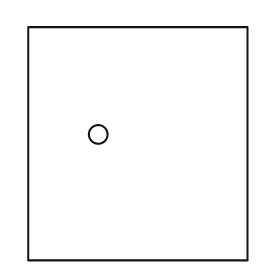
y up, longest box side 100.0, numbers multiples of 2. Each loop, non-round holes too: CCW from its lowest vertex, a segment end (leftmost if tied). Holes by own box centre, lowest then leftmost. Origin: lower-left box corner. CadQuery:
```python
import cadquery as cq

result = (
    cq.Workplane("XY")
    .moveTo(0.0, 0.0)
    .lineTo(94.0, 0.0)
    .lineTo(94.0, 100.0)
    .lineTo(0.0, 100.0)
    .close()
    .moveTo(30.0, 54.0)
    .circle(4.0)
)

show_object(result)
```